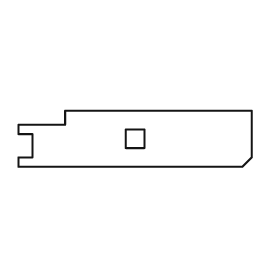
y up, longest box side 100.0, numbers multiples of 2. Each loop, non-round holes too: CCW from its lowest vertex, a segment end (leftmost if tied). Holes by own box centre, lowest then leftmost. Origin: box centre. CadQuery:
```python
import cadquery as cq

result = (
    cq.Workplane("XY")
    .moveTo(-50.0, -12.0)
    .lineTo(46.0, -12.0)
    .lineTo(50.0, -8.0)
    .lineTo(50.0, 12.0)
    .lineTo(-30.0, 12.0)
    .lineTo(-30.0, 6.0)
    .lineTo(-50.0, 6.0)
    .lineTo(-50.0, 2.0)
    .lineTo(-44.0, 2.0)
    .lineTo(-44.0, -8.0)
    .lineTo(-50.0, -8.0)
    .close()
    .moveTo(-4.0, -4.0)
    .lineTo(4.0, -4.0)
    .lineTo(4.0, 4.0)
    .lineTo(-4.0, 4.0)
    .close()
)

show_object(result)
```